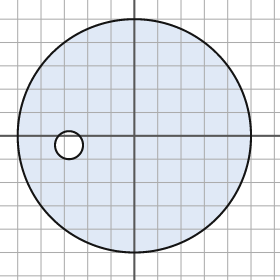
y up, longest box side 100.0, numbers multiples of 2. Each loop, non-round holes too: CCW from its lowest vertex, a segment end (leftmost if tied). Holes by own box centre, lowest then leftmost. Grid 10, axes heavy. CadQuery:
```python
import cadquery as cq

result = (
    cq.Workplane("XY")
    .moveTo(0.0, 0.0)
    .circle(50.0)
    .moveTo(-28.0, -4.0)
    .circle(6.0)
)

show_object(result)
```